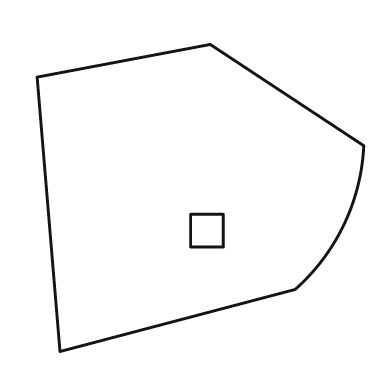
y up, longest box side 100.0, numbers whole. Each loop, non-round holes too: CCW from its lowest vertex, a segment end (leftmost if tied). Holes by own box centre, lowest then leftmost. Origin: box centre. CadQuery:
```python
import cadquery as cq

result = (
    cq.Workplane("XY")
    .moveTo(-43.0, -47.0)
    .lineTo(29.0, -28.0)
    .threePointArc((44.0, -8.0), (50.0, 16.0))
    .lineTo(3.0, 47.0)
    .lineTo(-50.0, 37.0)
    .close()
    .moveTo(-3.0, -15.0)
    .lineTo(7.0, -15.0)
    .lineTo(7.0, -5.0)
    .lineTo(-3.0, -5.0)
    .close()
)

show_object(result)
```